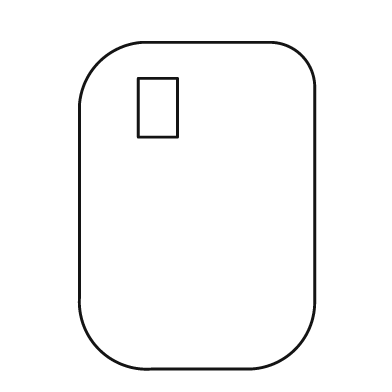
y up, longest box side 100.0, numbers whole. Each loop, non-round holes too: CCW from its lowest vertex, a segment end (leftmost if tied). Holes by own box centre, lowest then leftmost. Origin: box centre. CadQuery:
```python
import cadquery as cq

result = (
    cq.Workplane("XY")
    .moveTo(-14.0, -50.0)
    .lineTo(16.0, -50.0)
    .threePointArc((30.0, -44.0), (36.0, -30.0))
    .lineTo(36.0, 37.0)
    .threePointArc((32.0, 46.0), (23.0, 50.0))
    .lineTo(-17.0, 50.0)
    .threePointArc((-30.0, 44.0), (-36.0, 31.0))
    .lineTo(-36.0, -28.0)
    .threePointArc((-30.0, -44.0), (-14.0, -50.0))
    .close()
    .moveTo(-18.0, 21.0)
    .lineTo(-6.0, 21.0)
    .lineTo(-6.0, 39.0)
    .lineTo(-18.0, 39.0)
    .close()
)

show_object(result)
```